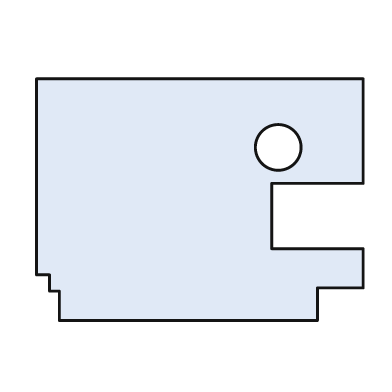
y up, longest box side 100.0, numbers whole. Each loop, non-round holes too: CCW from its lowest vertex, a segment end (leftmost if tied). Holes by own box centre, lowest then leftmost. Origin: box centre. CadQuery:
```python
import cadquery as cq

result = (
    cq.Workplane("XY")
    .moveTo(-43.0, -37.0)
    .lineTo(36.0, -37.0)
    .lineTo(36.0, -27.0)
    .lineTo(50.0, -27.0)
    .lineTo(50.0, -15.0)
    .lineTo(22.0, -15.0)
    .lineTo(22.0, 5.0)
    .lineTo(50.0, 5.0)
    .lineTo(50.0, 37.0)
    .lineTo(-50.0, 37.0)
    .lineTo(-50.0, -23.0)
    .lineTo(-46.0, -23.0)
    .lineTo(-46.0, -28.0)
    .lineTo(-43.0, -28.0)
    .close()
    .moveTo(24.0, 16.0)
    .circle(7.0)
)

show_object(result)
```